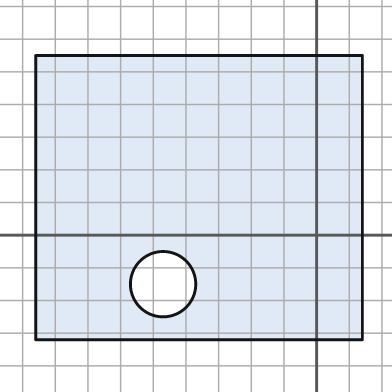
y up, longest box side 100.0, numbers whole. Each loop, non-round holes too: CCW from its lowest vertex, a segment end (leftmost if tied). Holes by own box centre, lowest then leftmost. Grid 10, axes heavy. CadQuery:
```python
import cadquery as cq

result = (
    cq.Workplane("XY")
    .moveTo(-86.0, -32.0)
    .lineTo(14.0, -32.0)
    .lineTo(14.0, 55.0)
    .lineTo(-86.0, 55.0)
    .close()
    .moveTo(-47.0, -15.0)
    .circle(10.0)
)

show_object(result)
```